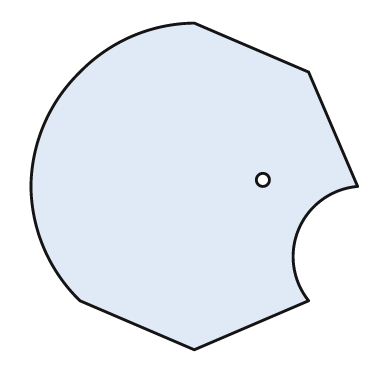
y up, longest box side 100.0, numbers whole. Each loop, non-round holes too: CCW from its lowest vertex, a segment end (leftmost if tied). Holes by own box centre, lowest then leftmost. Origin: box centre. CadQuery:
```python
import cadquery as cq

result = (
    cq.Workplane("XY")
    .moveTo(0.0, -50.0)
    .lineTo(35.0, -35.0)
    .threePointArc((32.0, -13.0), (50.0, 0.0))
    .lineTo(35.0, 35.0)
    .lineTo(0.0, 50.0)
    .threePointArc((-19.0, 46.0), (-35.0, 35.0))
    .threePointArc((-46.0, 19.0), (-50.0, 0.0))
    .threePointArc((-46.0, -19.0), (-35.0, -35.0))
    .close()
    .moveTo(21.0, 2.0)
    .circle(2.0)
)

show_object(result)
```